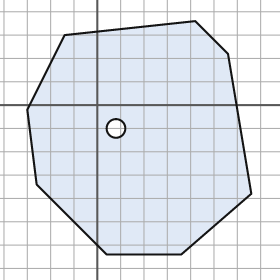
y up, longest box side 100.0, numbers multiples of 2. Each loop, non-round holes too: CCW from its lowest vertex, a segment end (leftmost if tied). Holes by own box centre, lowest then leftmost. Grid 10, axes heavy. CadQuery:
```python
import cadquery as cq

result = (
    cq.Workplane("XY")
    .moveTo(4.0, -64.0)
    .lineTo(36.0, -64.0)
    .lineTo(66.0, -38.0)
    .lineTo(56.0, 22.0)
    .lineTo(42.0, 36.0)
    .lineTo(-14.0, 30.0)
    .lineTo(-30.0, -2.0)
    .lineTo(-26.0, -34.0)
    .close()
    .moveTo(8.0, -10.0)
    .circle(4.0)
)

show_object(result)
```